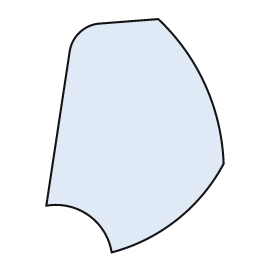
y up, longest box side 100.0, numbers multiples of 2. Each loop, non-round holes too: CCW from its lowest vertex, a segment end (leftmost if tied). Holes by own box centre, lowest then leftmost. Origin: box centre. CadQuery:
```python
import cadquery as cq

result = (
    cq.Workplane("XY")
    .moveTo(-10.0, -50.0)
    .threePointArc((18.0, -36.0), (38.0, -12.0))
    .threePointArc((30.0, 22.0), (10.0, 50.0))
    .lineTo(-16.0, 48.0)
    .threePointArc((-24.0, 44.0), (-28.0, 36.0))
    .lineTo(-38.0, -30.0)
    .threePointArc((-20.0, -34.0), (-10.0, -50.0))
    .close()
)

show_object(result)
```